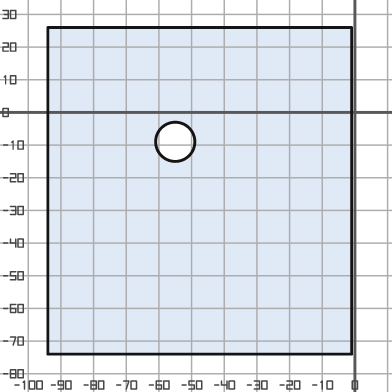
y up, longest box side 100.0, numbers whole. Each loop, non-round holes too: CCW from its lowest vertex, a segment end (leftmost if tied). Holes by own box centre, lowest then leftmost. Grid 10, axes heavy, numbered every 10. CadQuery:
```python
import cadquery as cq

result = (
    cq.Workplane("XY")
    .moveTo(-94.0, -74.0)
    .lineTo(-1.0, -74.0)
    .lineTo(-1.0, 26.0)
    .lineTo(-94.0, 26.0)
    .close()
    .moveTo(-55.0, -9.0)
    .circle(6.0)
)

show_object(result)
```